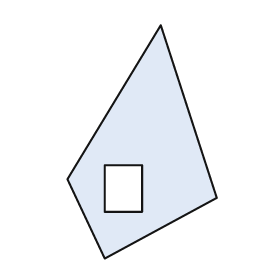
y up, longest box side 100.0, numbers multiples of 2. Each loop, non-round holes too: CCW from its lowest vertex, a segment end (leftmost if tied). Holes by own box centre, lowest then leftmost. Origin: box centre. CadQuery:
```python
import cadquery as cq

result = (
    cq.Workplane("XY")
    .moveTo(-16.0, -50.0)
    .lineTo(32.0, -24.0)
    .lineTo(8.0, 50.0)
    .lineTo(-32.0, -16.0)
    .close()
    .moveTo(-16.0, -30.0)
    .lineTo(0.0, -30.0)
    .lineTo(0.0, -10.0)
    .lineTo(-16.0, -10.0)
    .close()
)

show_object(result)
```